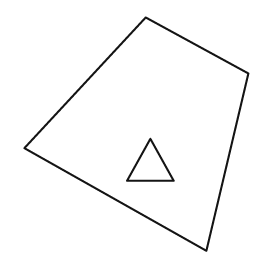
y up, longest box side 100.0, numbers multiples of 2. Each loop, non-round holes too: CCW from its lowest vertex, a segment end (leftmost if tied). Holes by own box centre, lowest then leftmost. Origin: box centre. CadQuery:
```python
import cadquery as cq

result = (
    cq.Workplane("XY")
    .moveTo(30.0, -50.0)
    .lineTo(48.0, 26.0)
    .lineTo(4.0, 50.0)
    .lineTo(-48.0, -6.0)
    .close()
    .moveTo(-4.0, -20.0)
    .lineTo(16.0, -20.0)
    .lineTo(6.0, -2.0)
    .close()
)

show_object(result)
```